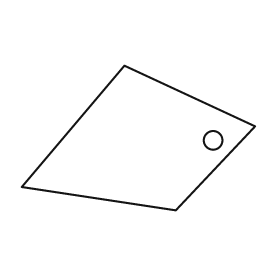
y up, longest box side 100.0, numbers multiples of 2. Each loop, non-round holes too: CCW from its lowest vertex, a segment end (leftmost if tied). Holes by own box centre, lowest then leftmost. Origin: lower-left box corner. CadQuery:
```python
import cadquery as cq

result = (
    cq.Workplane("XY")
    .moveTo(66.0, 0.0)
    .lineTo(100.0, 36.0)
    .lineTo(44.0, 62.0)
    .lineTo(0.0, 10.0)
    .close()
    .moveTo(82.0, 30.0)
    .circle(4.0)
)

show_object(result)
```